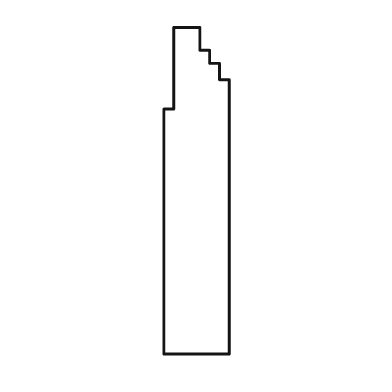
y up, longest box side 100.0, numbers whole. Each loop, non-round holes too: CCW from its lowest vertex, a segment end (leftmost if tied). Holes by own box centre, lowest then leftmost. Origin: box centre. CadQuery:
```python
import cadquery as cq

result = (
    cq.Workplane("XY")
    .moveTo(-10.0, -50.0)
    .lineTo(10.0, -50.0)
    .lineTo(10.0, 34.0)
    .lineTo(7.0, 34.0)
    .lineTo(7.0, 39.0)
    .lineTo(4.0, 39.0)
    .lineTo(4.0, 43.0)
    .lineTo(1.0, 43.0)
    .lineTo(1.0, 50.0)
    .lineTo(-7.0, 50.0)
    .lineTo(-7.0, 25.0)
    .lineTo(-10.0, 25.0)
    .close()
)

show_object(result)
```